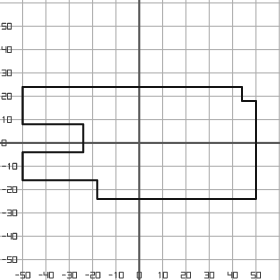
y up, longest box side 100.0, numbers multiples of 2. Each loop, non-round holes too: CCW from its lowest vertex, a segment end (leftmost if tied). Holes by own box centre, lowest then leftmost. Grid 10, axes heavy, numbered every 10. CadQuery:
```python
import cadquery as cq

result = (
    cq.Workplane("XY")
    .moveTo(-18.0, -24.0)
    .lineTo(50.0, -24.0)
    .lineTo(50.0, 18.0)
    .lineTo(44.0, 18.0)
    .lineTo(44.0, 24.0)
    .lineTo(-50.0, 24.0)
    .lineTo(-50.0, 8.0)
    .lineTo(-24.0, 8.0)
    .lineTo(-24.0, -4.0)
    .lineTo(-50.0, -4.0)
    .lineTo(-50.0, -16.0)
    .lineTo(-18.0, -16.0)
    .close()
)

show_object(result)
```